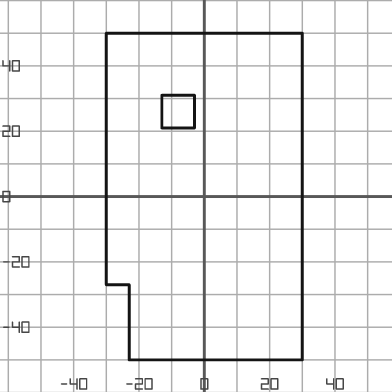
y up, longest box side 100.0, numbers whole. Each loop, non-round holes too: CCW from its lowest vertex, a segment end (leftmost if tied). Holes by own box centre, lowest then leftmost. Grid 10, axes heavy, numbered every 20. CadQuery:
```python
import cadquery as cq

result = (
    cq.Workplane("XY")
    .moveTo(-23.0, -50.0)
    .lineTo(30.0, -50.0)
    .lineTo(30.0, 50.0)
    .lineTo(-30.0, 50.0)
    .lineTo(-30.0, -27.0)
    .lineTo(-23.0, -27.0)
    .close()
    .moveTo(-13.0, 21.0)
    .lineTo(-3.0, 21.0)
    .lineTo(-3.0, 31.0)
    .lineTo(-13.0, 31.0)
    .close()
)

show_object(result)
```